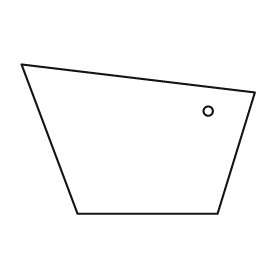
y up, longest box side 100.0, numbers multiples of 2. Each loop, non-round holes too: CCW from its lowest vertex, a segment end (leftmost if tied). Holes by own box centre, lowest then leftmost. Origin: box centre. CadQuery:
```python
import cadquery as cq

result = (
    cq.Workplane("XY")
    .moveTo(-26.0, -32.0)
    .lineTo(34.0, -32.0)
    .lineTo(50.0, 20.0)
    .lineTo(-50.0, 32.0)
    .close()
    .moveTo(30.0, 12.0)
    .circle(2.0)
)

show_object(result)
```